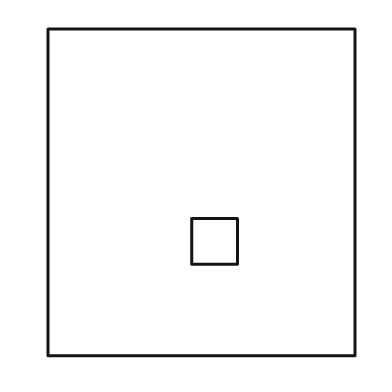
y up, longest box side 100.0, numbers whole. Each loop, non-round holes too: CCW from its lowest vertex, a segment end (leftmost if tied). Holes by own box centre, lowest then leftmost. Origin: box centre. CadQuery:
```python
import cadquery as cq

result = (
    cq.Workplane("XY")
    .moveTo(-47.0, -50.0)
    .lineTo(47.0, -50.0)
    .lineTo(47.0, 50.0)
    .lineTo(-47.0, 50.0)
    .close()
    .moveTo(-3.0, -22.0)
    .lineTo(11.0, -22.0)
    .lineTo(11.0, -8.0)
    .lineTo(-3.0, -8.0)
    .close()
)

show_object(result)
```